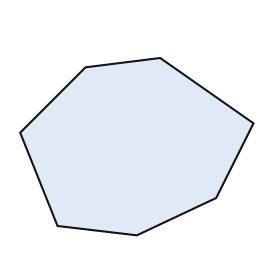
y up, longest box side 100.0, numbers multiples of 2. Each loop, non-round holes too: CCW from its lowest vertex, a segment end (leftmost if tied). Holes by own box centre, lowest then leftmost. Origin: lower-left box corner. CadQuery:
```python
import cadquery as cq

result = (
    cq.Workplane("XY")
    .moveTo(50.0, 0.0)
    .lineTo(84.0, 16.0)
    .lineTo(100.0, 48.0)
    .lineTo(60.0, 76.0)
    .lineTo(28.0, 72.0)
    .lineTo(0.0, 44.0)
    .lineTo(16.0, 4.0)
    .close()
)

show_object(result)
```